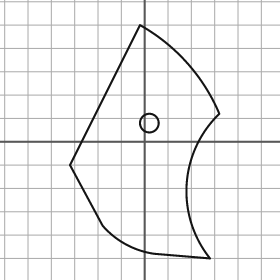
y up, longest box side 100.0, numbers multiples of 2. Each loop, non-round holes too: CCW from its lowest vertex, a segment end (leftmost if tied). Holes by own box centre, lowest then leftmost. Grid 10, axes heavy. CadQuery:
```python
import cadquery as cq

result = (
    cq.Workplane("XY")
    .moveTo(28.0, -50.0)
    .threePointArc((18.0, -18.0), (32.0, 12.0))
    .threePointArc((18.0, 34.0), (-2.0, 50.0))
    .lineTo(-32.0, -10.0)
    .lineTo(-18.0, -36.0)
    .threePointArc((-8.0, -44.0), (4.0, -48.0))
    .close()
    .moveTo(2.0, 8.0)
    .circle(4.0)
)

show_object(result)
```